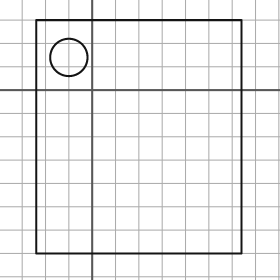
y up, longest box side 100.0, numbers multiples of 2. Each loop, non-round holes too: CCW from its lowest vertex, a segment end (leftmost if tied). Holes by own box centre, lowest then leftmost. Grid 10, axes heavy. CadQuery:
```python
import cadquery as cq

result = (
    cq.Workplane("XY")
    .moveTo(-24.0, -70.0)
    .lineTo(64.0, -70.0)
    .lineTo(64.0, 30.0)
    .lineTo(-24.0, 30.0)
    .close()
    .moveTo(-10.0, 14.0)
    .circle(8.0)
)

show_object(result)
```